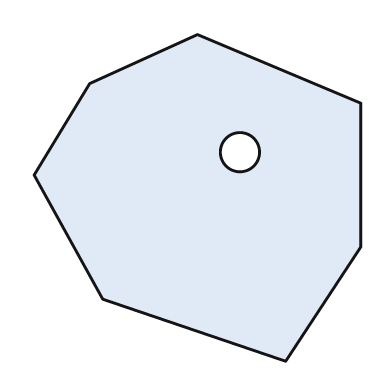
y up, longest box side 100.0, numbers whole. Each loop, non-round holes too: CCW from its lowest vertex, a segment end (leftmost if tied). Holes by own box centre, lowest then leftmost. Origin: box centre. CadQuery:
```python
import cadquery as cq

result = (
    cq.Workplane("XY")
    .moveTo(27.0, -50.0)
    .lineTo(50.0, -15.0)
    .lineTo(50.0, 29.0)
    .lineTo(0.0, 50.0)
    .lineTo(-33.0, 35.0)
    .lineTo(-50.0, 7.0)
    .lineTo(-29.0, -31.0)
    .close()
    .moveTo(13.0, 14.0)
    .circle(6.0)
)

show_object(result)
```